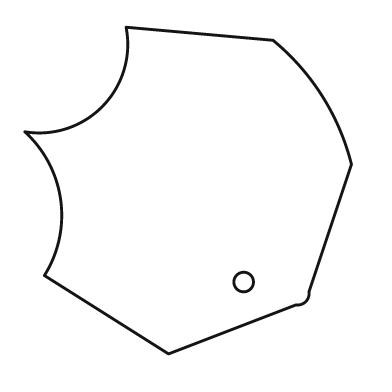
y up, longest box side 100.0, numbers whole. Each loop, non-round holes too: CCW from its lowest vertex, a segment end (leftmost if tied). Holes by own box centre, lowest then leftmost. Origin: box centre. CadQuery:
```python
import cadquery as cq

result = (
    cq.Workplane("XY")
    .moveTo(-6.0, -50.0)
    .lineTo(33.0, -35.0)
    .threePointArc((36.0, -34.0), (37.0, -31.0))
    .lineTo(50.0, 8.0)
    .threePointArc((41.0, 29.0), (26.0, 46.0))
    .lineTo(-19.0, 50.0)
    .threePointArc((-26.0, 26.0), (-50.0, 18.0))
    .threePointArc((-39.0, -3.0), (-44.0, -26.0))
    .close()
    .moveTo(17.0, -28.0)
    .circle(3.0)
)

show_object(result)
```